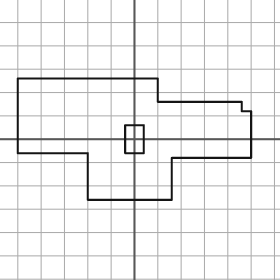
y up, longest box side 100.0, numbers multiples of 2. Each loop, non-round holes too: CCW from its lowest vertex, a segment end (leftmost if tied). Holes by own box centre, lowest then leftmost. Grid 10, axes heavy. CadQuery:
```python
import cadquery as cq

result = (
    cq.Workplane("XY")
    .moveTo(-20.0, -26.0)
    .lineTo(16.0, -26.0)
    .lineTo(16.0, -8.0)
    .lineTo(50.0, -8.0)
    .lineTo(50.0, 12.0)
    .lineTo(46.0, 12.0)
    .lineTo(46.0, 16.0)
    .lineTo(10.0, 16.0)
    .lineTo(10.0, 26.0)
    .lineTo(-50.0, 26.0)
    .lineTo(-50.0, -6.0)
    .lineTo(-20.0, -6.0)
    .close()
    .moveTo(-4.0, -6.0)
    .lineTo(4.0, -6.0)
    .lineTo(4.0, 6.0)
    .lineTo(-4.0, 6.0)
    .close()
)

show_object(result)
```